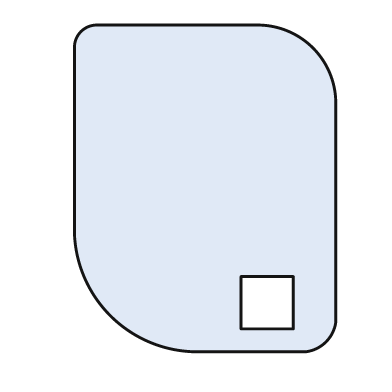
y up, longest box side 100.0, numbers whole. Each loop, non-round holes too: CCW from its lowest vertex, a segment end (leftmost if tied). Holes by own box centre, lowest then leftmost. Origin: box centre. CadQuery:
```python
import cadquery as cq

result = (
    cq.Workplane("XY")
    .moveTo(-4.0, -50.0)
    .lineTo(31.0, -50.0)
    .threePointArc((37.0, -47.0), (40.0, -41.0))
    .lineTo(40.0, 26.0)
    .threePointArc((33.0, 43.0), (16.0, 50.0))
    .lineTo(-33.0, 50.0)
    .threePointArc((-38.0, 48.0), (-40.0, 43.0))
    .lineTo(-40.0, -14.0)
    .threePointArc((-29.0, -39.0), (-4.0, -50.0))
    .close()
    .moveTo(11.0, -43.0)
    .lineTo(27.0, -43.0)
    .lineTo(27.0, -27.0)
    .lineTo(11.0, -27.0)
    .close()
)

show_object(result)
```